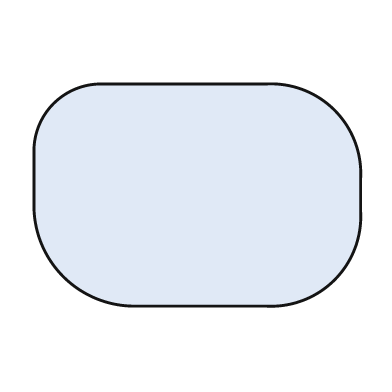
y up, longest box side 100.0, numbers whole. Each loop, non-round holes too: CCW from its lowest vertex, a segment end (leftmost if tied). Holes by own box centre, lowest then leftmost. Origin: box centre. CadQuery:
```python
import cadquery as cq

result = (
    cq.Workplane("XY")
    .moveTo(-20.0, -34.0)
    .lineTo(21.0, -34.0)
    .threePointArc((42.0, -26.0), (50.0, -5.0))
    .lineTo(50.0, 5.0)
    .threePointArc((42.0, 26.0), (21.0, 34.0))
    .lineTo(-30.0, 34.0)
    .threePointArc((-44.0, 28.0), (-50.0, 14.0))
    .lineTo(-50.0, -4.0)
    .threePointArc((-41.0, -25.0), (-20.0, -34.0))
    .close()
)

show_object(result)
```